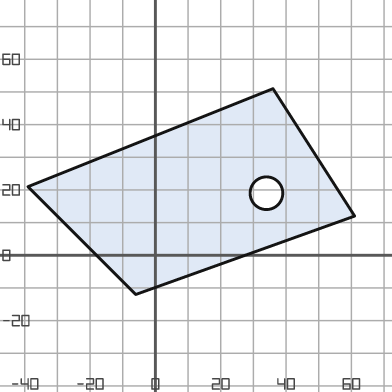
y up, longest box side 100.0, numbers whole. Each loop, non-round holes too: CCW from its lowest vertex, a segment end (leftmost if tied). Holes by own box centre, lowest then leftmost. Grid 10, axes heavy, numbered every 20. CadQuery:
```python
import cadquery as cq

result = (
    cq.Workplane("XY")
    .moveTo(-6.0, -12.0)
    .lineTo(61.0, 12.0)
    .lineTo(36.0, 51.0)
    .lineTo(-39.0, 21.0)
    .close()
    .moveTo(34.0, 19.0)
    .circle(5.0)
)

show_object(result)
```